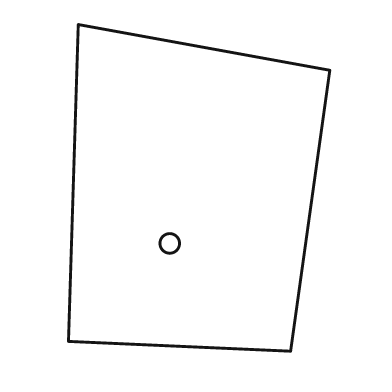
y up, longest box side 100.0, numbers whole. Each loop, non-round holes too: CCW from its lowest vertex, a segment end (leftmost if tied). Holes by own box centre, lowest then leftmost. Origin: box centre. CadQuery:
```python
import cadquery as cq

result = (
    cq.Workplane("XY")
    .moveTo(28.0, -50.0)
    .lineTo(40.0, 36.0)
    .lineTo(-37.0, 50.0)
    .lineTo(-40.0, -47.0)
    .close()
    .moveTo(-9.0, -17.0)
    .circle(3.0)
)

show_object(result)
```